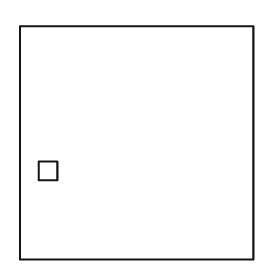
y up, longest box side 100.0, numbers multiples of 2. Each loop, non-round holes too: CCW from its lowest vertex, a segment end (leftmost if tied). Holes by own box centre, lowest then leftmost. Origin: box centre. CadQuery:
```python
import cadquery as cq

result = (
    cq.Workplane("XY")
    .moveTo(-50.0, -50.0)
    .lineTo(50.0, -50.0)
    .lineTo(50.0, 50.0)
    .lineTo(-50.0, 50.0)
    .close()
    .moveTo(-42.0, -16.0)
    .lineTo(-34.0, -16.0)
    .lineTo(-34.0, -8.0)
    .lineTo(-42.0, -8.0)
    .close()
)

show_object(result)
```